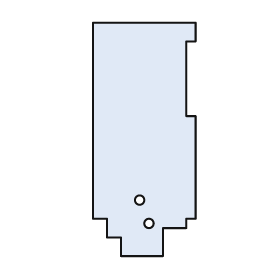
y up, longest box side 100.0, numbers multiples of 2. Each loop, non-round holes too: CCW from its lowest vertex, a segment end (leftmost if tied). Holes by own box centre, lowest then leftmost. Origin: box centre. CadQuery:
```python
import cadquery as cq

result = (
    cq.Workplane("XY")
    .moveTo(-10.0, -50.0)
    .lineTo(8.0, -50.0)
    .lineTo(8.0, -38.0)
    .lineTo(18.0, -38.0)
    .lineTo(18.0, -34.0)
    .lineTo(22.0, -34.0)
    .lineTo(22.0, 10.0)
    .lineTo(18.0, 10.0)
    .lineTo(18.0, 42.0)
    .lineTo(22.0, 42.0)
    .lineTo(22.0, 50.0)
    .lineTo(-22.0, 50.0)
    .lineTo(-22.0, -34.0)
    .lineTo(-16.0, -34.0)
    .lineTo(-16.0, -42.0)
    .lineTo(-10.0, -42.0)
    .close()
    .moveTo(2.0, -36.0)
    .circle(2.0)
    .moveTo(-2.0, -26.0)
    .circle(2.0)
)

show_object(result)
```